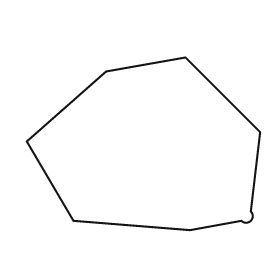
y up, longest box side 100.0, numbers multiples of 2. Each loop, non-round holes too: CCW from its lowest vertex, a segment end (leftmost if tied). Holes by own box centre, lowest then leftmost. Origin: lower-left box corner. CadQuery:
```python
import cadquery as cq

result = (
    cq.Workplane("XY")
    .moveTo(70.0, 0.0)
    .lineTo(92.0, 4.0)
    .threePointArc((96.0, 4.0), (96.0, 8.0))
    .lineTo(100.0, 42.0)
    .lineTo(68.0, 74.0)
    .lineTo(34.0, 68.0)
    .lineTo(0.0, 38.0)
    .lineTo(20.0, 4.0)
    .close()
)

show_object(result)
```